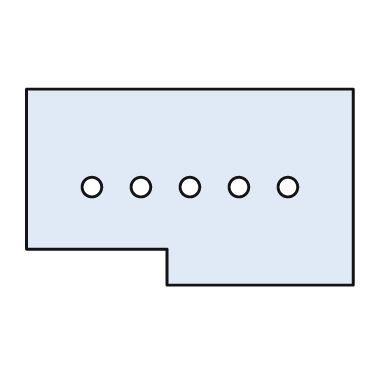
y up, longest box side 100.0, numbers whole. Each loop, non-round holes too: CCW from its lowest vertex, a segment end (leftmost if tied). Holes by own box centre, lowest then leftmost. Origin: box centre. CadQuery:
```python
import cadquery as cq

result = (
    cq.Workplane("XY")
    .moveTo(-7.0, -30.0)
    .lineTo(50.0, -30.0)
    .lineTo(50.0, 30.0)
    .lineTo(-50.0, 30.0)
    .lineTo(-50.0, -19.0)
    .lineTo(-7.0, -19.0)
    .close()
    .moveTo(-30.0, 0.0)
    .circle(3.0)
    .moveTo(-15.0, 0.0)
    .circle(3.0)
    .moveTo(0.0, 0.0)
    .circle(3.0)
    .moveTo(15.0, 0.0)
    .circle(3.0)
    .moveTo(30.0, 0.0)
    .circle(3.0)
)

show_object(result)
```